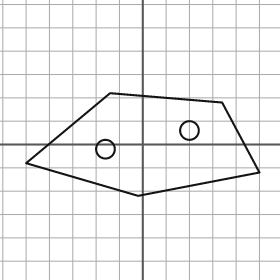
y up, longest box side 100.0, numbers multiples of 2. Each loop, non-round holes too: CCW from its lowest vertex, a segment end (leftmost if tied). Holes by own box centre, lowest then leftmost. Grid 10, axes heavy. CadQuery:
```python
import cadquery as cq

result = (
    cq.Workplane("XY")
    .moveTo(-2.0, -22.0)
    .lineTo(50.0, -12.0)
    .lineTo(34.0, 18.0)
    .lineTo(-14.0, 22.0)
    .lineTo(-50.0, -8.0)
    .close()
    .moveTo(-16.0, -2.0)
    .circle(4.0)
    .moveTo(20.0, 6.0)
    .circle(4.0)
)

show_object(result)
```